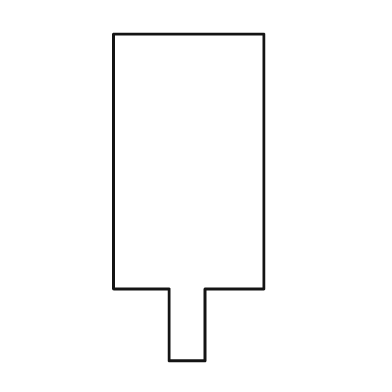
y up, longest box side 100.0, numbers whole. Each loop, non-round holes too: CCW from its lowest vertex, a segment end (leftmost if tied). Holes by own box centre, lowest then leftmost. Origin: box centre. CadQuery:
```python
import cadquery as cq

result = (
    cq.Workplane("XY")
    .moveTo(-6.0, -50.0)
    .lineTo(5.0, -50.0)
    .lineTo(5.0, -28.0)
    .lineTo(23.0, -28.0)
    .lineTo(23.0, 50.0)
    .lineTo(-23.0, 50.0)
    .lineTo(-23.0, -28.0)
    .lineTo(-6.0, -28.0)
    .close()
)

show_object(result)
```